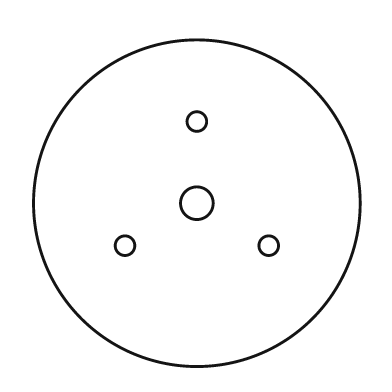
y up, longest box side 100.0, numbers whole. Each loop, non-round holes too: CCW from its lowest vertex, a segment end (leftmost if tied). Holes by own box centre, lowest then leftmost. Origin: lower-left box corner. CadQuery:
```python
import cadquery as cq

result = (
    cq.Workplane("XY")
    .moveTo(50.0, 50.0)
    .circle(50.0)
    .moveTo(28.0, 37.0)
    .circle(3.0)
    .moveTo(72.0, 37.0)
    .circle(3.0)
    .moveTo(50.0, 50.0)
    .circle(5.0)
    .moveTo(50.0, 75.0)
    .circle(3.0)
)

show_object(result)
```